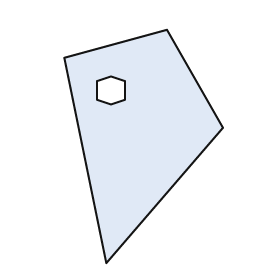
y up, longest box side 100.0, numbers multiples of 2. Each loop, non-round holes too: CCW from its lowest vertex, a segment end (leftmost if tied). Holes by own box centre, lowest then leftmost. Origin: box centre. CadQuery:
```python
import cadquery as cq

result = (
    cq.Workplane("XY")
    .moveTo(-16.0, -50.0)
    .lineTo(34.0, 8.0)
    .lineTo(10.0, 50.0)
    .lineTo(-34.0, 38.0)
    .close()
    .moveTo(-14.0, 18.0)
    .lineTo(-8.0, 20.0)
    .lineTo(-8.0, 28.0)
    .lineTo(-14.0, 30.0)
    .lineTo(-20.0, 28.0)
    .lineTo(-20.0, 20.0)
    .close()
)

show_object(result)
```